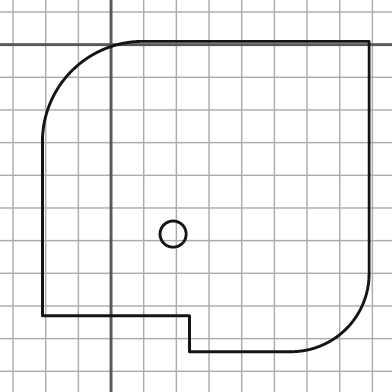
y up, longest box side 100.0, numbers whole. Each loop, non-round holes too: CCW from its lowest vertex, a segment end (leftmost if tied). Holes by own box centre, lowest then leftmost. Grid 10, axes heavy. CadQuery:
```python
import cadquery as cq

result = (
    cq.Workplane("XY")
    .moveTo(24.0, -94.0)
    .lineTo(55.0, -94.0)
    .threePointArc((72.0, -87.0), (79.0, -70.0))
    .lineTo(79.0, 1.0)
    .lineTo(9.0, 1.0)
    .threePointArc((-12.0, -8.0), (-21.0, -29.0))
    .lineTo(-21.0, -83.0)
    .lineTo(24.0, -83.0)
    .close()
    .moveTo(19.0, -58.0)
    .circle(4.0)
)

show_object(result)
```